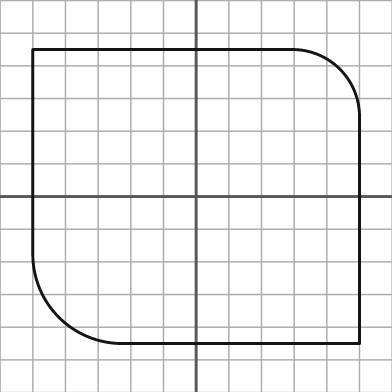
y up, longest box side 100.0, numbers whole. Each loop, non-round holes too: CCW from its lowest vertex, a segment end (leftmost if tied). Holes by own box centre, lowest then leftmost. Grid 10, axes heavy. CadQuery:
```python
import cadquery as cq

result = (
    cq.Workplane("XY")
    .moveTo(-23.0, -45.0)
    .lineTo(50.0, -45.0)
    .lineTo(50.0, 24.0)
    .threePointArc((44.0, 39.0), (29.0, 45.0))
    .lineTo(-50.0, 45.0)
    .lineTo(-50.0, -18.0)
    .threePointArc((-42.0, -37.0), (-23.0, -45.0))
    .close()
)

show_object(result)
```